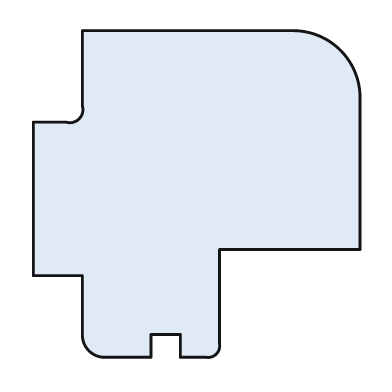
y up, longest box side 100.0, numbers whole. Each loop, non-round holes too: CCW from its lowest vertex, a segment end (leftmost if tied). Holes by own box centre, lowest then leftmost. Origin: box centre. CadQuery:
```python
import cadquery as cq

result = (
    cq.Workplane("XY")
    .moveTo(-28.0, -50.0)
    .lineTo(-14.0, -50.0)
    .lineTo(-14.0, -43.0)
    .lineTo(-5.0, -43.0)
    .lineTo(-5.0, -50.0)
    .lineTo(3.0, -50.0)
    .threePointArc((6.0, -49.0), (7.0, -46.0))
    .lineTo(7.0, -17.0)
    .lineTo(50.0, -17.0)
    .lineTo(50.0, 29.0)
    .threePointArc((44.0, 44.0), (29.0, 50.0))
    .lineTo(-35.0, 50.0)
    .lineTo(-35.0, 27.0)
    .threePointArc((-36.0, 23.0), (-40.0, 22.0))
    .lineTo(-50.0, 22.0)
    .lineTo(-50.0, -25.0)
    .lineTo(-35.0, -25.0)
    .lineTo(-35.0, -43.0)
    .threePointArc((-33.0, -48.0), (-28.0, -50.0))
    .close()
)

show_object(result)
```